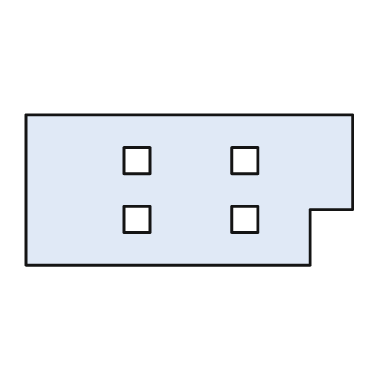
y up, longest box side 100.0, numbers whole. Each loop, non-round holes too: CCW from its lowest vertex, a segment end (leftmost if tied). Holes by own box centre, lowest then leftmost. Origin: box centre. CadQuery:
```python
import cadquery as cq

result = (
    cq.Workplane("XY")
    .moveTo(-50.0, -23.0)
    .lineTo(37.0, -23.0)
    .lineTo(37.0, -6.0)
    .lineTo(50.0, -6.0)
    .lineTo(50.0, 23.0)
    .lineTo(-50.0, 23.0)
    .close()
    .moveTo(-20.0, -13.0)
    .lineTo(-12.0, -13.0)
    .lineTo(-12.0, -5.0)
    .lineTo(-20.0, -5.0)
    .close()
    .moveTo(13.0, -13.0)
    .lineTo(21.0, -13.0)
    .lineTo(21.0, -5.0)
    .lineTo(13.0, -5.0)
    .close()
    .moveTo(-20.0, 5.0)
    .lineTo(-12.0, 5.0)
    .lineTo(-12.0, 13.0)
    .lineTo(-20.0, 13.0)
    .close()
    .moveTo(13.0, 5.0)
    .lineTo(21.0, 5.0)
    .lineTo(21.0, 13.0)
    .lineTo(13.0, 13.0)
    .close()
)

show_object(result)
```